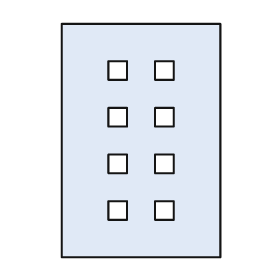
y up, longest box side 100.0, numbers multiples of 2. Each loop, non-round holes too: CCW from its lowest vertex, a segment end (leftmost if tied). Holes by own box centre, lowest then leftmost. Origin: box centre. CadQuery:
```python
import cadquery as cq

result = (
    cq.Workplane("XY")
    .moveTo(-34.0, -50.0)
    .lineTo(34.0, -50.0)
    .lineTo(34.0, 50.0)
    .lineTo(-34.0, 50.0)
    .close()
    .moveTo(-14.0, -34.0)
    .lineTo(-6.0, -34.0)
    .lineTo(-6.0, -26.0)
    .lineTo(-14.0, -26.0)
    .close()
    .moveTo(6.0, -34.0)
    .lineTo(14.0, -34.0)
    .lineTo(14.0, -26.0)
    .lineTo(6.0, -26.0)
    .close()
    .moveTo(-14.0, -14.0)
    .lineTo(-6.0, -14.0)
    .lineTo(-6.0, -6.0)
    .lineTo(-14.0, -6.0)
    .close()
    .moveTo(6.0, -14.0)
    .lineTo(14.0, -14.0)
    .lineTo(14.0, -6.0)
    .lineTo(6.0, -6.0)
    .close()
    .moveTo(-14.0, 6.0)
    .lineTo(-6.0, 6.0)
    .lineTo(-6.0, 14.0)
    .lineTo(-14.0, 14.0)
    .close()
    .moveTo(6.0, 6.0)
    .lineTo(14.0, 6.0)
    .lineTo(14.0, 14.0)
    .lineTo(6.0, 14.0)
    .close()
    .moveTo(-14.0, 26.0)
    .lineTo(-6.0, 26.0)
    .lineTo(-6.0, 34.0)
    .lineTo(-14.0, 34.0)
    .close()
    .moveTo(6.0, 26.0)
    .lineTo(14.0, 26.0)
    .lineTo(14.0, 34.0)
    .lineTo(6.0, 34.0)
    .close()
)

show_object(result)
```